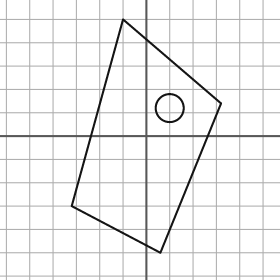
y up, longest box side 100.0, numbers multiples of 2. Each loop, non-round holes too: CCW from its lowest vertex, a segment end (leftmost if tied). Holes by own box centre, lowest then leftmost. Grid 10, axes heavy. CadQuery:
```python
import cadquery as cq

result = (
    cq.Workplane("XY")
    .moveTo(6.0, -50.0)
    .lineTo(32.0, 14.0)
    .lineTo(-10.0, 50.0)
    .lineTo(-32.0, -30.0)
    .close()
    .moveTo(10.0, 12.0)
    .circle(6.0)
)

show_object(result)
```